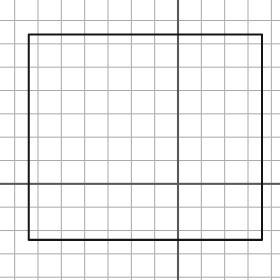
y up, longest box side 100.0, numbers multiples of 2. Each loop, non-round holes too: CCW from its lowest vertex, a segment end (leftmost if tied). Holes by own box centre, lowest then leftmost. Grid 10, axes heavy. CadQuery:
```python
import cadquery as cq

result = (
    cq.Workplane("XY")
    .moveTo(-64.0, -24.0)
    .lineTo(36.0, -24.0)
    .lineTo(36.0, 64.0)
    .lineTo(-64.0, 64.0)
    .close()
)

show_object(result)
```